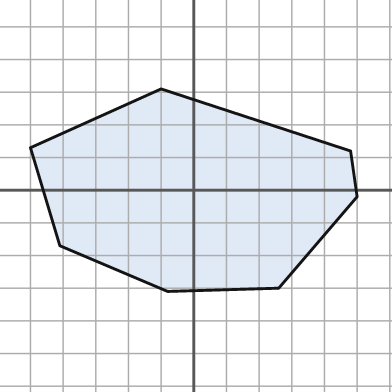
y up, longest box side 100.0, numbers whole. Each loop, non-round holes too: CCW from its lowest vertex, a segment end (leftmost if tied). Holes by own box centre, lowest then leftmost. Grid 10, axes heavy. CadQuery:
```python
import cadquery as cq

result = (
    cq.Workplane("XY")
    .moveTo(-8.0, -31.0)
    .lineTo(26.0, -30.0)
    .lineTo(50.0, -2.0)
    .lineTo(48.0, 12.0)
    .lineTo(-10.0, 31.0)
    .lineTo(-50.0, 13.0)
    .lineTo(-41.0, -17.0)
    .close()
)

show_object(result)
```